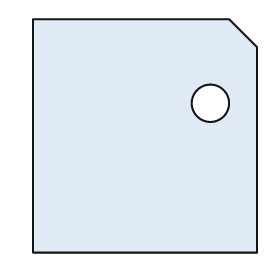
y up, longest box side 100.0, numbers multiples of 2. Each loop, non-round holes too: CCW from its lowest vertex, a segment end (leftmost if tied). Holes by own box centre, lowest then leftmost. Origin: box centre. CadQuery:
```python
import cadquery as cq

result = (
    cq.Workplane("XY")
    .moveTo(-48.0, -50.0)
    .lineTo(48.0, -50.0)
    .lineTo(48.0, 38.0)
    .lineTo(36.0, 50.0)
    .lineTo(-48.0, 50.0)
    .close()
    .moveTo(28.0, 14.0)
    .circle(8.0)
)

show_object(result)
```